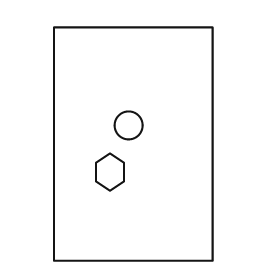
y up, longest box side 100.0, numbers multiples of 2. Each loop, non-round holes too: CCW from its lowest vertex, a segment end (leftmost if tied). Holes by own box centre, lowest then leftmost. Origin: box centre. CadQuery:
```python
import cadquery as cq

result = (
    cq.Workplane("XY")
    .moveTo(-34.0, -50.0)
    .lineTo(34.0, -50.0)
    .lineTo(34.0, 50.0)
    .lineTo(-34.0, 50.0)
    .close()
    .moveTo(-10.0, -20.0)
    .lineTo(-4.0, -16.0)
    .lineTo(-4.0, -8.0)
    .lineTo(-10.0, -4.0)
    .lineTo(-16.0, -8.0)
    .lineTo(-16.0, -16.0)
    .close()
    .moveTo(-2.0, 8.0)
    .circle(6.0)
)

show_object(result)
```